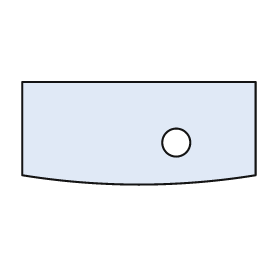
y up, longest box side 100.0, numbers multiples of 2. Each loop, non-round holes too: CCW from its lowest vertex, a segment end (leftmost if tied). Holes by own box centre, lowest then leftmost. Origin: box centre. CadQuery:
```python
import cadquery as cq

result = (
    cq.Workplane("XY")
    .moveTo(-50.0, -18.0)
    .threePointArc((0.0, -22.0), (50.0, -18.0))
    .lineTo(50.0, 22.0)
    .lineTo(-50.0, 22.0)
    .close()
    .moveTo(16.0, -4.0)
    .circle(6.0)
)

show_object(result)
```